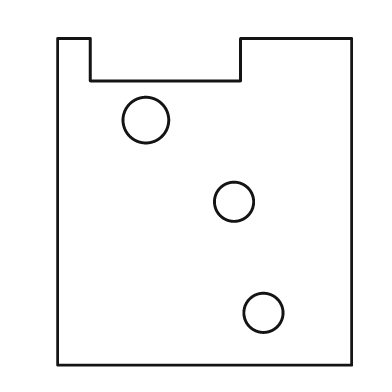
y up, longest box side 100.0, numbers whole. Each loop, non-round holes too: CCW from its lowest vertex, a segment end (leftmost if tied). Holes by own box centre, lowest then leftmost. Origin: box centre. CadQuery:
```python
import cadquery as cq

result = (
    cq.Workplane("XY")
    .moveTo(-45.0, -50.0)
    .lineTo(45.0, -50.0)
    .lineTo(45.0, 50.0)
    .lineTo(11.0, 50.0)
    .lineTo(11.0, 37.0)
    .lineTo(-35.0, 37.0)
    .lineTo(-35.0, 50.0)
    .lineTo(-45.0, 50.0)
    .close()
    .moveTo(18.0, -34.0)
    .circle(6.0)
    .moveTo(9.0, 0.0)
    .circle(6.0)
    .moveTo(-18.0, 25.0)
    .circle(7.0)
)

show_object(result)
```